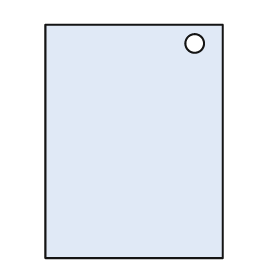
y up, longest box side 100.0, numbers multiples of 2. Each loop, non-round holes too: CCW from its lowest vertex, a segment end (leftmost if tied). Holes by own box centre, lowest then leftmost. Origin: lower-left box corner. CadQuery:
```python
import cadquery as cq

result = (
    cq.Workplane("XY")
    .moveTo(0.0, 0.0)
    .lineTo(76.0, 0.0)
    .lineTo(76.0, 100.0)
    .lineTo(0.0, 100.0)
    .close()
    .moveTo(64.0, 92.0)
    .circle(4.0)
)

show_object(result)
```